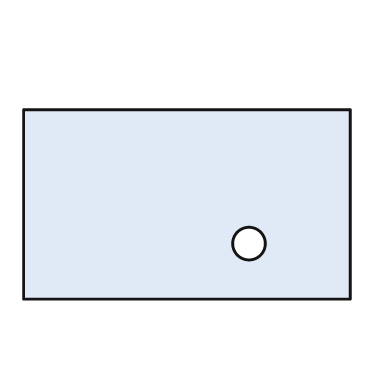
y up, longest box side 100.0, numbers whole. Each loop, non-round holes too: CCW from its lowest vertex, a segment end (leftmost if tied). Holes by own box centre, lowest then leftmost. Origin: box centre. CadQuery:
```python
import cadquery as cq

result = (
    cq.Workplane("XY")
    .moveTo(-50.0, -29.0)
    .lineTo(50.0, -29.0)
    .lineTo(50.0, 29.0)
    .lineTo(-50.0, 29.0)
    .close()
    .moveTo(19.0, -12.0)
    .circle(5.0)
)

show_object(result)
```